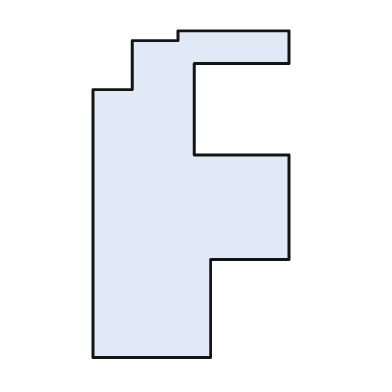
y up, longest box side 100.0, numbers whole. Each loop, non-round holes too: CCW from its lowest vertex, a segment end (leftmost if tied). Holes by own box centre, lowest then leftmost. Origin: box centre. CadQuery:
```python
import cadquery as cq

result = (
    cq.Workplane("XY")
    .moveTo(-30.0, -50.0)
    .lineTo(6.0, -50.0)
    .lineTo(6.0, -20.0)
    .lineTo(30.0, -20.0)
    .lineTo(30.0, 12.0)
    .lineTo(1.0, 12.0)
    .lineTo(1.0, 40.0)
    .lineTo(30.0, 40.0)
    .lineTo(30.0, 50.0)
    .lineTo(-4.0, 50.0)
    .lineTo(-4.0, 47.0)
    .lineTo(-18.0, 47.0)
    .lineTo(-18.0, 32.0)
    .lineTo(-30.0, 32.0)
    .close()
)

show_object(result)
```